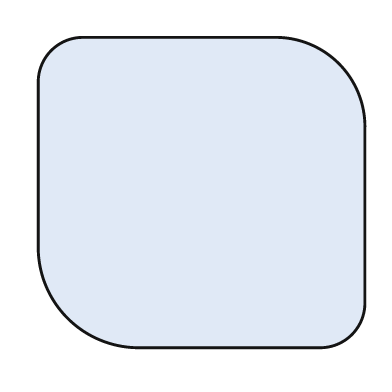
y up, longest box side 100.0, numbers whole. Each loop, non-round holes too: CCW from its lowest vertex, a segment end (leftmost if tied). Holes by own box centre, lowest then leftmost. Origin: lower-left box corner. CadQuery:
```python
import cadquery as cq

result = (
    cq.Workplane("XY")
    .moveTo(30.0, 0.0)
    .lineTo(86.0, 0.0)
    .threePointArc((96.0, 4.0), (100.0, 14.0))
    .lineTo(100.0, 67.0)
    .threePointArc((92.0, 87.0), (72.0, 95.0))
    .lineTo(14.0, 95.0)
    .threePointArc((4.0, 91.0), (0.0, 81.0))
    .lineTo(0.0, 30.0)
    .threePointArc((9.0, 9.0), (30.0, 0.0))
    .close()
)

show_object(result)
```